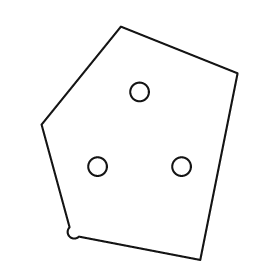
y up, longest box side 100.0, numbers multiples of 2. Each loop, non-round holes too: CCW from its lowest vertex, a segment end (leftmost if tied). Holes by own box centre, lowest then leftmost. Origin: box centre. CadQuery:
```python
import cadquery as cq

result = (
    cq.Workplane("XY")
    .moveTo(26.0, -50.0)
    .lineTo(42.0, 30.0)
    .lineTo(-8.0, 50.0)
    .lineTo(-42.0, 8.0)
    .lineTo(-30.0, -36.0)
    .threePointArc((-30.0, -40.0), (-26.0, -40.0))
    .close()
    .moveTo(-18.0, -10.0)
    .circle(4.0)
    .moveTo(18.0, -10.0)
    .circle(4.0)
    .moveTo(0.0, 22.0)
    .circle(4.0)
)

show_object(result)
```